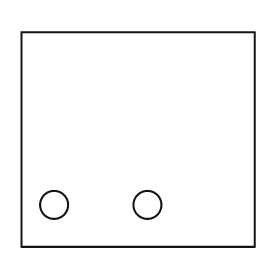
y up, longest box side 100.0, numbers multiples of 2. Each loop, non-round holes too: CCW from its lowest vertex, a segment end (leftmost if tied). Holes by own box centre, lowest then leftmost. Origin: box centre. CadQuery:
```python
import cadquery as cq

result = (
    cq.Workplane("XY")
    .moveTo(-50.0, -46.0)
    .lineTo(50.0, -46.0)
    .lineTo(50.0, 46.0)
    .lineTo(-50.0, 46.0)
    .close()
    .moveTo(-36.0, -28.0)
    .circle(6.0)
    .moveTo(4.0, -28.0)
    .circle(6.0)
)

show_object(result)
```